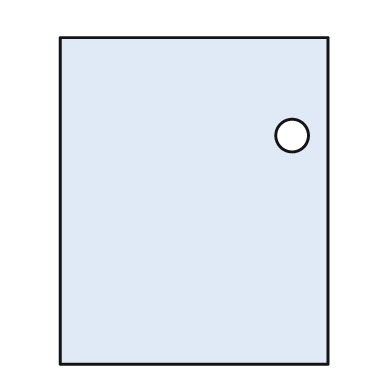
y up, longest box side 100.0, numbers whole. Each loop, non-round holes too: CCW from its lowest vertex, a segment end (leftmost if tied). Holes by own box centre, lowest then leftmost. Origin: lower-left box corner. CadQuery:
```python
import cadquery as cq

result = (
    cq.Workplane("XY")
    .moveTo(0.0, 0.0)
    .lineTo(82.0, 0.0)
    .lineTo(82.0, 100.0)
    .lineTo(0.0, 100.0)
    .close()
    .moveTo(71.0, 70.0)
    .circle(5.0)
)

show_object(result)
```